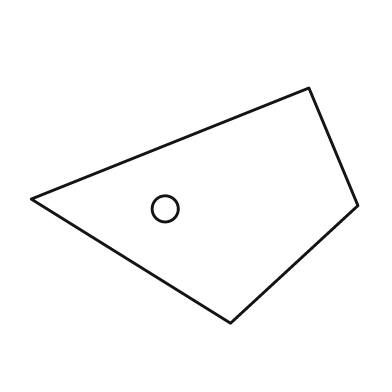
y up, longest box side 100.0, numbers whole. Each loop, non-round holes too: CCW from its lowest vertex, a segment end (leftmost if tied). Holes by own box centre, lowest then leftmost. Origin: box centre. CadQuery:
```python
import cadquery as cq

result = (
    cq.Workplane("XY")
    .moveTo(11.0, -36.0)
    .lineTo(50.0, 0.0)
    .lineTo(35.0, 36.0)
    .lineTo(-50.0, 2.0)
    .close()
    .moveTo(-9.0, -1.0)
    .circle(4.0)
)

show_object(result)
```